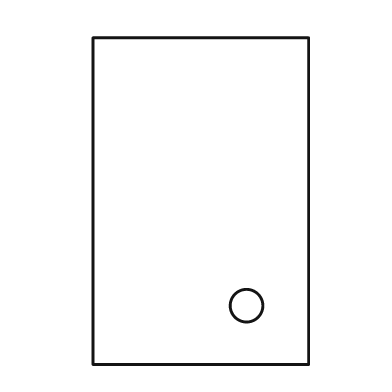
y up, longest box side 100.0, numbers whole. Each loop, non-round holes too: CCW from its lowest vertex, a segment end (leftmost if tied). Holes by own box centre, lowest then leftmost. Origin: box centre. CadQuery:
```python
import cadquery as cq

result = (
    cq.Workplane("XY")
    .moveTo(-33.0, -50.0)
    .lineTo(33.0, -50.0)
    .lineTo(33.0, 50.0)
    .lineTo(-33.0, 50.0)
    .close()
    .moveTo(14.0, -32.0)
    .circle(5.0)
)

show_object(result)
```